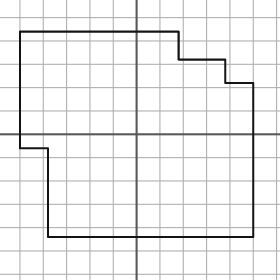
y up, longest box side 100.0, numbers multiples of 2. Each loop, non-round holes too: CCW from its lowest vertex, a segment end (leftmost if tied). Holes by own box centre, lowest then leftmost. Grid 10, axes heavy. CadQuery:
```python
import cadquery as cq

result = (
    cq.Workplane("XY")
    .moveTo(-38.0, -44.0)
    .lineTo(50.0, -44.0)
    .lineTo(50.0, 22.0)
    .lineTo(38.0, 22.0)
    .lineTo(38.0, 32.0)
    .lineTo(18.0, 32.0)
    .lineTo(18.0, 44.0)
    .lineTo(-50.0, 44.0)
    .lineTo(-50.0, -6.0)
    .lineTo(-38.0, -6.0)
    .close()
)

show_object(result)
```